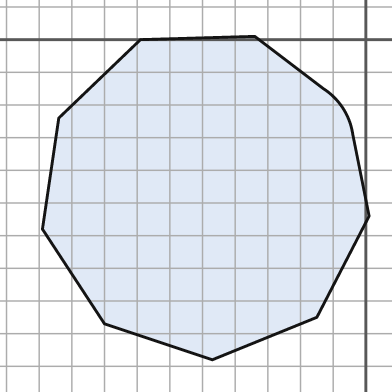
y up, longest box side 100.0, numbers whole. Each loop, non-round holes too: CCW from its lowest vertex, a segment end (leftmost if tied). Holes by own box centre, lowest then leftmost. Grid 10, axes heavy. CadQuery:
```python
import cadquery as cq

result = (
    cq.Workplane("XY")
    .moveTo(-47.0, -98.0)
    .lineTo(-15.0, -85.0)
    .lineTo(1.0, -54.0)
    .lineTo(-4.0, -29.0)
    .threePointArc((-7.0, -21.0), (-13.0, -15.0))
    .lineTo(-34.0, 1.0)
    .lineTo(-69.0, 0.0)
    .lineTo(-94.0, -24.0)
    .lineTo(-99.0, -58.0)
    .lineTo(-80.0, -87.0)
    .close()
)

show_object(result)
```